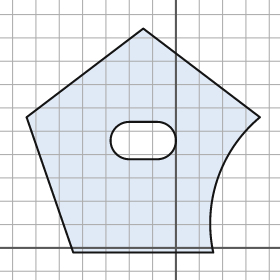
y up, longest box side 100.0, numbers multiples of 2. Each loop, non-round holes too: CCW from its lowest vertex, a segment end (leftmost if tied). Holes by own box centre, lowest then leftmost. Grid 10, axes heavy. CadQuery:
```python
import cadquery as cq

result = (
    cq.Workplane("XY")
    .moveTo(-44.0, -2.0)
    .lineTo(16.0, -2.0)
    .threePointArc((18.0, 30.0), (36.0, 56.0))
    .lineTo(-14.0, 94.0)
    .lineTo(-64.0, 56.0)
    .close()
    .moveTo(-20.0, 38.0)
    .lineTo(-8.0, 38.0)
    .threePointArc((0.0, 46.0), (-8.0, 54.0))
    .lineTo(-20.0, 54.0)
    .threePointArc((-28.0, 46.0), (-20.0, 38.0))
    .close()
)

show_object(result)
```